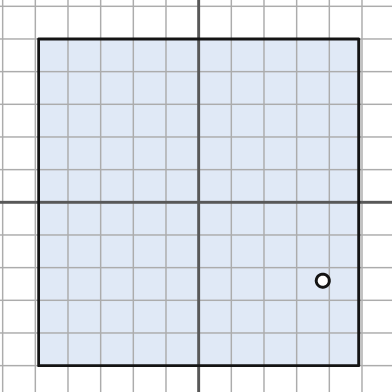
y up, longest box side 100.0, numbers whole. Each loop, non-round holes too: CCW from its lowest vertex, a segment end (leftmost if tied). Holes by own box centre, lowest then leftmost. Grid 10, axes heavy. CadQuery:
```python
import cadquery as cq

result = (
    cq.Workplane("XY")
    .moveTo(-49.0, -50.0)
    .lineTo(49.0, -50.0)
    .lineTo(49.0, 50.0)
    .lineTo(-49.0, 50.0)
    .close()
    .moveTo(38.0, -24.0)
    .circle(2.0)
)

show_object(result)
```